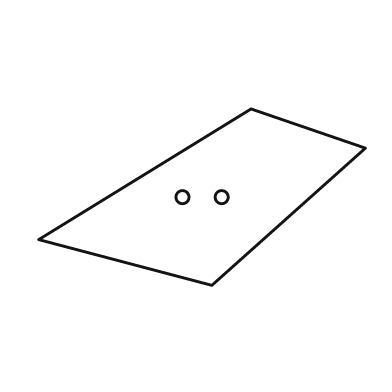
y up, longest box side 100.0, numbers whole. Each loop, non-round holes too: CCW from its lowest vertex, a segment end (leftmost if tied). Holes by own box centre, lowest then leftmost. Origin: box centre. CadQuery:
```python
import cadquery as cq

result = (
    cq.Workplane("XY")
    .moveTo(3.0, -27.0)
    .lineTo(50.0, 15.0)
    .lineTo(15.0, 27.0)
    .lineTo(-50.0, -13.0)
    .close()
    .moveTo(-6.0, 0.0)
    .circle(2.0)
    .moveTo(6.0, 0.0)
    .circle(2.0)
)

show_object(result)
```